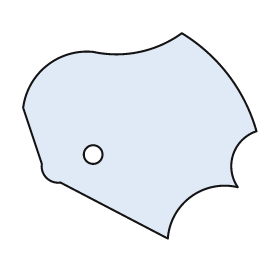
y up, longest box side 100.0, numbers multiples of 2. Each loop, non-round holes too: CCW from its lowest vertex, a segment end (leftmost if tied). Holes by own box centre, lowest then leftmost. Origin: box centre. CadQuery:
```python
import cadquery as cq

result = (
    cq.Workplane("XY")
    .moveTo(12.0, -44.0)
    .threePointArc((22.0, -26.0), (42.0, -22.0))
    .threePointArc((40.0, -8.0), (50.0, 2.0))
    .threePointArc((38.0, 26.0), (18.0, 44.0))
    .threePointArc((0.0, 36.0), (-20.0, 36.0))
    .threePointArc((-40.0, 30.0), (-50.0, 12.0))
    .lineTo(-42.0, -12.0)
    .threePointArc((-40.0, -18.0), (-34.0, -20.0))
    .close()
    .moveTo(-20.0, -8.0)
    .circle(4.0)
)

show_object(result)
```